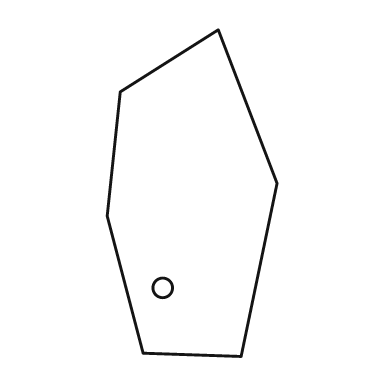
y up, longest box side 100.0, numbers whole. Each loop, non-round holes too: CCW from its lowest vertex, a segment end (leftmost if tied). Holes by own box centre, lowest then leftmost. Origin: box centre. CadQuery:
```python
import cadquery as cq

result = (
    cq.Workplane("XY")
    .moveTo(15.0, -50.0)
    .lineTo(26.0, 3.0)
    .lineTo(8.0, 50.0)
    .lineTo(-22.0, 31.0)
    .lineTo(-26.0, -7.0)
    .lineTo(-15.0, -49.0)
    .close()
    .moveTo(-9.0, -29.0)
    .circle(3.0)
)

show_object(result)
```